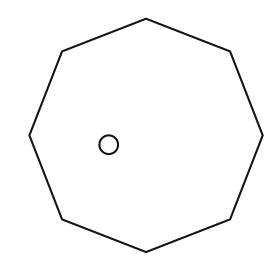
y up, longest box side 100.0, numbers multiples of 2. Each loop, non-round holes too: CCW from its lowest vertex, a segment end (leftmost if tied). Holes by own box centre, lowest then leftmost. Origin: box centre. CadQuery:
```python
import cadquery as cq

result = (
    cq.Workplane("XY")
    .moveTo(0.0, -50.0)
    .lineTo(36.0, -36.0)
    .lineTo(50.0, 0.0)
    .lineTo(36.0, 36.0)
    .lineTo(0.0, 50.0)
    .lineTo(-36.0, 36.0)
    .lineTo(-50.0, 0.0)
    .lineTo(-36.0, -36.0)
    .close()
    .moveTo(-16.0, -4.0)
    .circle(4.0)
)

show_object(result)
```